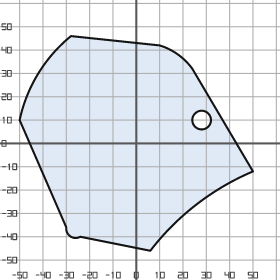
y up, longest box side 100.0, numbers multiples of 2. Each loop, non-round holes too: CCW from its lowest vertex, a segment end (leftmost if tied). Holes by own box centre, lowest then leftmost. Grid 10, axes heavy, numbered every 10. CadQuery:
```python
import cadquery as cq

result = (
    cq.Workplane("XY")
    .moveTo(6.0, -46.0)
    .threePointArc((26.0, -26.0), (50.0, -12.0))
    .lineTo(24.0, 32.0)
    .threePointArc((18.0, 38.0), (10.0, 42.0))
    .lineTo(-28.0, 46.0)
    .threePointArc((-42.0, 30.0), (-50.0, 10.0))
    .lineTo(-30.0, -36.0)
    .threePointArc((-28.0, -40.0), (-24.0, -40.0))
    .close()
    .moveTo(28.0, 10.0)
    .circle(4.0)
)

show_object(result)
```